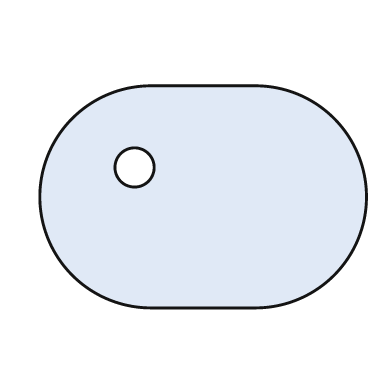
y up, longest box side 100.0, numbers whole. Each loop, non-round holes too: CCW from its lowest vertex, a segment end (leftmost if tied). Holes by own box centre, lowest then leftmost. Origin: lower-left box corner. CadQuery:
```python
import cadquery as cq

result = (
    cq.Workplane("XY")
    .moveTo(34.0, 0.0)
    .lineTo(66.0, 0.0)
    .threePointArc((100.0, 34.0), (66.0, 68.0))
    .lineTo(34.0, 68.0)
    .threePointArc((0.0, 34.0), (34.0, 0.0))
    .close()
    .moveTo(29.0, 43.0)
    .circle(6.0)
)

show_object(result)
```